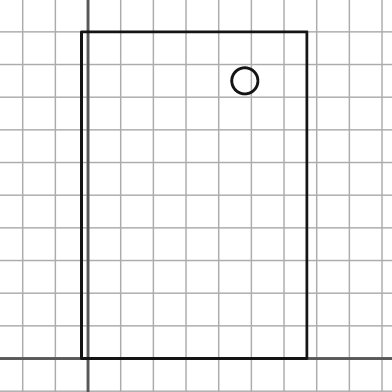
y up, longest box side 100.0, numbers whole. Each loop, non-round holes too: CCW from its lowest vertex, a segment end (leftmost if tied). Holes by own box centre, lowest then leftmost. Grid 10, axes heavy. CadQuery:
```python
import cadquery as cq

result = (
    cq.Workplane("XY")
    .moveTo(-2.0, 0.0)
    .lineTo(67.0, 0.0)
    .lineTo(67.0, 100.0)
    .lineTo(-2.0, 100.0)
    .close()
    .moveTo(48.0, 85.0)
    .circle(4.0)
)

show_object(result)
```